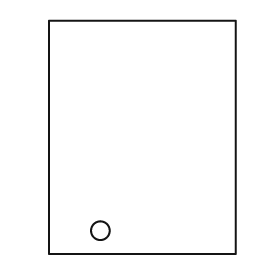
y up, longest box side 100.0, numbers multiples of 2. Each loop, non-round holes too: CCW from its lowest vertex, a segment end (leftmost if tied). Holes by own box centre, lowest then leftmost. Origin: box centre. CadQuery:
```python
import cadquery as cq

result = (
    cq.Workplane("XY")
    .moveTo(-40.0, -50.0)
    .lineTo(40.0, -50.0)
    .lineTo(40.0, 50.0)
    .lineTo(-40.0, 50.0)
    .close()
    .moveTo(-18.0, -40.0)
    .circle(4.0)
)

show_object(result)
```